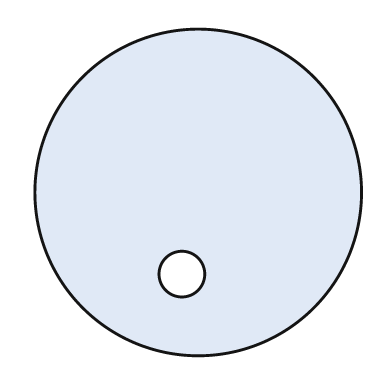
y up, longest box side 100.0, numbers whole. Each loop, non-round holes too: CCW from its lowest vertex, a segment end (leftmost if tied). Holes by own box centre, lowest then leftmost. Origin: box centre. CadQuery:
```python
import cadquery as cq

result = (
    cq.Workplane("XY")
    .moveTo(0.0, 0.0)
    .circle(50.0)
    .moveTo(-5.0, -25.0)
    .circle(7.0)
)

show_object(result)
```